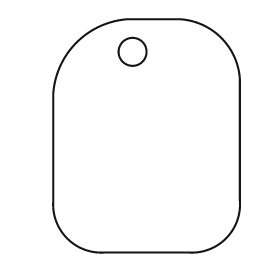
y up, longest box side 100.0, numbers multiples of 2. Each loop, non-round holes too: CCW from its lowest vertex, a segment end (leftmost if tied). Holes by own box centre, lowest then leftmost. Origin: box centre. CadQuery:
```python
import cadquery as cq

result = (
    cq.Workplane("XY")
    .moveTo(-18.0, -50.0)
    .lineTo(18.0, -50.0)
    .threePointArc((34.0, -44.0), (40.0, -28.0))
    .lineTo(40.0, 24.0)
    .threePointArc((32.0, 42.0), (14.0, 50.0))
    .lineTo(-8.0, 50.0)
    .threePointArc((-30.0, 40.0), (-40.0, 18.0))
    .lineTo(-40.0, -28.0)
    .threePointArc((-34.0, -44.0), (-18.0, -50.0))
    .close()
    .moveTo(-6.0, 36.0)
    .circle(6.0)
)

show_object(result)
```